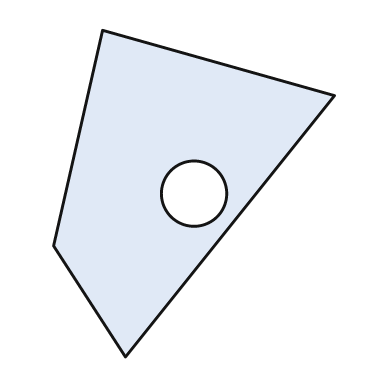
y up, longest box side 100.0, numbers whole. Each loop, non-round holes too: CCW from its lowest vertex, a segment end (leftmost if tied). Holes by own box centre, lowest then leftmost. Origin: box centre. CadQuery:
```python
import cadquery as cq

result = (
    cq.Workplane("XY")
    .moveTo(-21.0, -50.0)
    .lineTo(43.0, 30.0)
    .lineTo(-28.0, 50.0)
    .lineTo(-43.0, -16.0)
    .close()
    .moveTo(0.0, 0.0)
    .circle(10.0)
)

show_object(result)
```